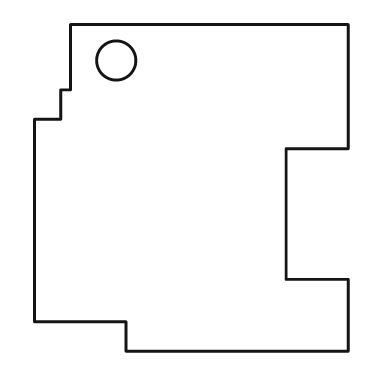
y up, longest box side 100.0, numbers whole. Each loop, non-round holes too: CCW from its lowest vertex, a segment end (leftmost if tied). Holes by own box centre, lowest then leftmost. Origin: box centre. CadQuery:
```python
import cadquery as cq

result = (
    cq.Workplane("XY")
    .moveTo(-20.0, -50.0)
    .lineTo(48.0, -50.0)
    .lineTo(48.0, -28.0)
    .lineTo(29.0, -28.0)
    .lineTo(29.0, 12.0)
    .lineTo(48.0, 12.0)
    .lineTo(48.0, 50.0)
    .lineTo(-37.0, 50.0)
    .lineTo(-37.0, 30.0)
    .lineTo(-40.0, 30.0)
    .lineTo(-40.0, 21.0)
    .lineTo(-48.0, 21.0)
    .lineTo(-48.0, -41.0)
    .lineTo(-20.0, -41.0)
    .close()
    .moveTo(-23.0, 39.0)
    .circle(6.0)
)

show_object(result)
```